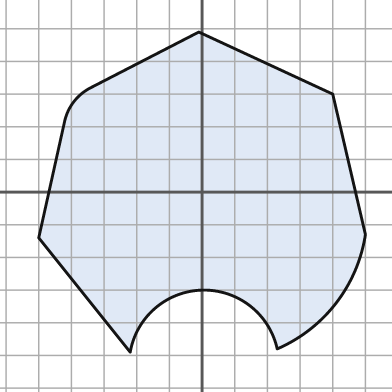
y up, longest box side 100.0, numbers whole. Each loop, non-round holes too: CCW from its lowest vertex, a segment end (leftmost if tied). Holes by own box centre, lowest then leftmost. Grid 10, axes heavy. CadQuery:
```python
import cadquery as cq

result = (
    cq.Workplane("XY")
    .moveTo(-22.0, -49.0)
    .threePointArc((0.0, -30.0), (23.0, -48.0))
    .threePointArc((41.0, -34.0), (50.0, -13.0))
    .lineTo(40.0, 30.0)
    .lineTo(-1.0, 49.0)
    .lineTo(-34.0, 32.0)
    .threePointArc((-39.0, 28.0), (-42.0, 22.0))
    .lineTo(-50.0, -14.0)
    .close()
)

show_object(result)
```